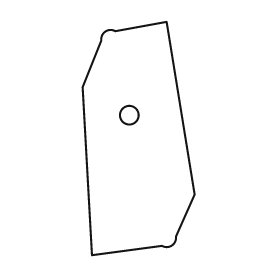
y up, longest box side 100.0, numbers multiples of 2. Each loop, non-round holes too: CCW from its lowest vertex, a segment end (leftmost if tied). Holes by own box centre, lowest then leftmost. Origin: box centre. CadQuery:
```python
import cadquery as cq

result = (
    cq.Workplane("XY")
    .moveTo(-20.0, -50.0)
    .lineTo(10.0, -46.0)
    .threePointArc((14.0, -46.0), (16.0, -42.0))
    .lineTo(24.0, -24.0)
    .lineTo(12.0, 50.0)
    .lineTo(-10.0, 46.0)
    .threePointArc((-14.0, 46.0), (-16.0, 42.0))
    .lineTo(-24.0, 22.0)
    .close()
    .moveTo(-4.0, 10.0)
    .circle(4.0)
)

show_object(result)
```